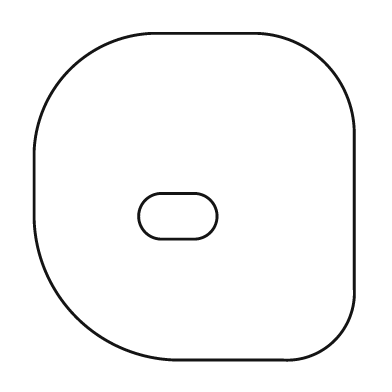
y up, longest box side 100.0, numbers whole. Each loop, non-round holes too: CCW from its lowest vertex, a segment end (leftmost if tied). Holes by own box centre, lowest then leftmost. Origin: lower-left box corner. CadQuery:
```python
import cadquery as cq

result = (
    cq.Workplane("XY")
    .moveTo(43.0, 0.0)
    .lineTo(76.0, 0.0)
    .threePointArc((92.0, 6.0), (98.0, 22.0))
    .lineTo(98.0, 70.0)
    .threePointArc((89.0, 91.0), (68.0, 100.0))
    .lineTo(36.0, 100.0)
    .threePointArc((11.0, 89.0), (0.0, 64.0))
    .lineTo(0.0, 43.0)
    .threePointArc((13.0, 13.0), (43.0, 0.0))
    .close()
    .moveTo(39.0, 37.0)
    .lineTo(49.0, 37.0)
    .threePointArc((56.0, 44.0), (49.0, 51.0))
    .lineTo(39.0, 51.0)
    .threePointArc((32.0, 44.0), (39.0, 37.0))
    .close()
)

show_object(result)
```